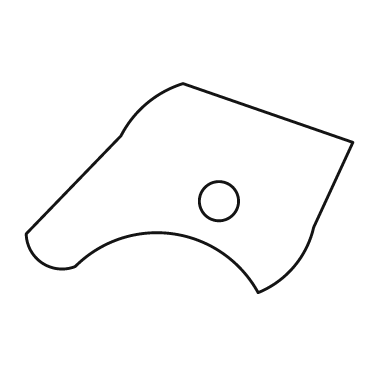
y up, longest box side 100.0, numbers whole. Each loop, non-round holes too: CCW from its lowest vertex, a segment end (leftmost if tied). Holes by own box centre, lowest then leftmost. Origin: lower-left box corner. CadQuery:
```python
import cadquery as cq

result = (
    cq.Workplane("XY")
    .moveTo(71.0, 0.0)
    .threePointArc((82.0, 8.0), (88.0, 20.0))
    .lineTo(100.0, 46.0)
    .lineTo(48.0, 64.0)
    .threePointArc((37.0, 58.0), (29.0, 48.0))
    .lineTo(0.0, 18.0)
    .threePointArc((5.0, 9.0), (15.0, 8.0))
    .threePointArc((45.0, 18.0), (71.0, 0.0))
    .close()
    .moveTo(59.0, 28.0)
    .circle(6.0)
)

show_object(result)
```